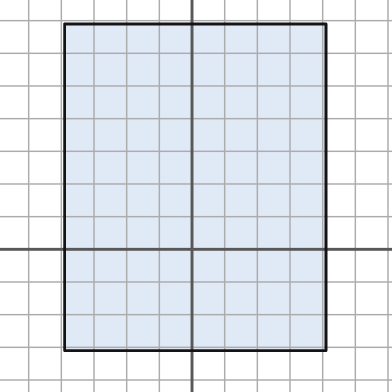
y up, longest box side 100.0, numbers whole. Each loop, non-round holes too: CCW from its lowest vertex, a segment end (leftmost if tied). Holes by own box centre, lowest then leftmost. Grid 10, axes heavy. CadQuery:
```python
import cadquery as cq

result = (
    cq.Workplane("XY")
    .moveTo(-39.0, -31.0)
    .lineTo(41.0, -31.0)
    .lineTo(41.0, 69.0)
    .lineTo(-39.0, 69.0)
    .close()
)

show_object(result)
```